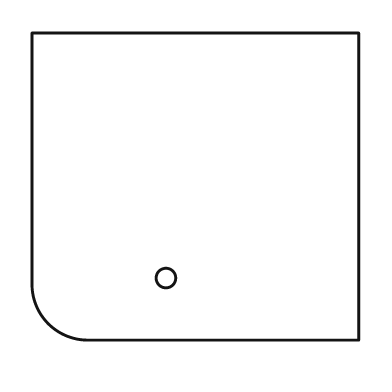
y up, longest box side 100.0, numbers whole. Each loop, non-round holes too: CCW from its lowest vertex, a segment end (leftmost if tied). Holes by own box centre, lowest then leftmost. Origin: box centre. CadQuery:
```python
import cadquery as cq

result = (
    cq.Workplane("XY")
    .moveTo(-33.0, -47.0)
    .lineTo(50.0, -47.0)
    .lineTo(50.0, 47.0)
    .lineTo(-50.0, 47.0)
    .lineTo(-50.0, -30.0)
    .threePointArc((-45.0, -42.0), (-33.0, -47.0))
    .close()
    .moveTo(-9.0, -28.0)
    .circle(3.0)
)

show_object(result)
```